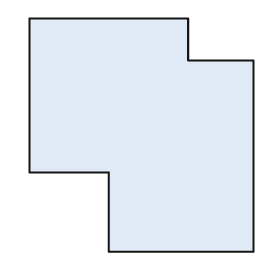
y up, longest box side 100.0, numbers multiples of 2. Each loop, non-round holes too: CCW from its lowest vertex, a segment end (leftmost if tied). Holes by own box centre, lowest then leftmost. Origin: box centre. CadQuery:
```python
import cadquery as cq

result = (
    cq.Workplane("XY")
    .moveTo(-14.0, -50.0)
    .lineTo(48.0, -50.0)
    .lineTo(48.0, 32.0)
    .lineTo(20.0, 32.0)
    .lineTo(20.0, 50.0)
    .lineTo(-48.0, 50.0)
    .lineTo(-48.0, -16.0)
    .lineTo(-14.0, -16.0)
    .close()
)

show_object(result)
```